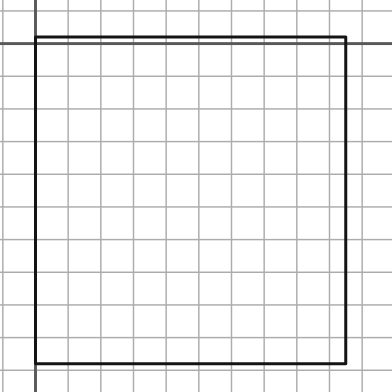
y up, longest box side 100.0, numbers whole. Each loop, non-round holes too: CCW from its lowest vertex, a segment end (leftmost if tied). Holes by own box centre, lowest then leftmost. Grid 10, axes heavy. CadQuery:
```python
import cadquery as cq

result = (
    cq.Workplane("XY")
    .moveTo(0.0, -98.0)
    .lineTo(95.0, -98.0)
    .lineTo(95.0, 2.0)
    .lineTo(0.0, 2.0)
    .close()
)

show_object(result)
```